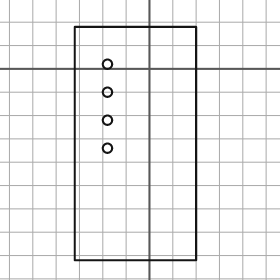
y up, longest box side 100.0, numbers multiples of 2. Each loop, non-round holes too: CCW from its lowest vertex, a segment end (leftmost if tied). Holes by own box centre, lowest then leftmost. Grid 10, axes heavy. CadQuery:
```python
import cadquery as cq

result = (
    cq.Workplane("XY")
    .moveTo(-32.0, -82.0)
    .lineTo(20.0, -82.0)
    .lineTo(20.0, 18.0)
    .lineTo(-32.0, 18.0)
    .close()
    .moveTo(-18.0, -34.0)
    .circle(2.0)
    .moveTo(-18.0, -22.0)
    .circle(2.0)
    .moveTo(-18.0, -10.0)
    .circle(2.0)
    .moveTo(-18.0, 2.0)
    .circle(2.0)
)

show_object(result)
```